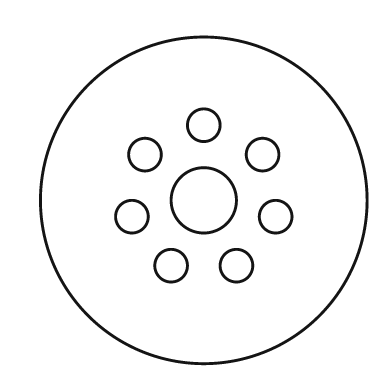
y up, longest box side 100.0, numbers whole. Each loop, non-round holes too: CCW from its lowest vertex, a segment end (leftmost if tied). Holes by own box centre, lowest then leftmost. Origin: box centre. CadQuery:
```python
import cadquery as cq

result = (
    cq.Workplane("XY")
    .moveTo(0.0, 0.0)
    .circle(50.0)
    .moveTo(-10.0, -20.0)
    .circle(5.0)
    .moveTo(10.0, -20.0)
    .circle(5.0)
    .moveTo(-22.0, -5.0)
    .circle(5.0)
    .moveTo(22.0, -5.0)
    .circle(5.0)
    .moveTo(0.0, 0.0)
    .circle(10.0)
    .moveTo(-18.0, 14.0)
    .circle(5.0)
    .moveTo(18.0, 14.0)
    .circle(5.0)
    .moveTo(0.0, 23.0)
    .circle(5.0)
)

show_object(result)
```